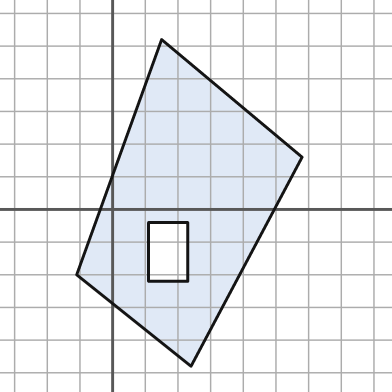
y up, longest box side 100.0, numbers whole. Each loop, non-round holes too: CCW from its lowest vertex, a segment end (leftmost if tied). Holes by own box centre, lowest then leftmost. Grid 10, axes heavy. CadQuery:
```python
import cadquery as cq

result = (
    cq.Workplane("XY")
    .moveTo(24.0, -48.0)
    .lineTo(58.0, 16.0)
    .lineTo(15.0, 52.0)
    .lineTo(-11.0, -20.0)
    .close()
    .moveTo(11.0, -22.0)
    .lineTo(23.0, -22.0)
    .lineTo(23.0, -4.0)
    .lineTo(11.0, -4.0)
    .close()
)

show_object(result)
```